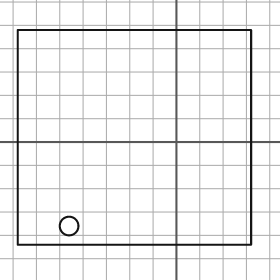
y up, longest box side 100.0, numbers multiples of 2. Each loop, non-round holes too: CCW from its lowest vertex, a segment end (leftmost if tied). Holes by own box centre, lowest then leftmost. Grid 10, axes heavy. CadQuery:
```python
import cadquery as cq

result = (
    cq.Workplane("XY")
    .moveTo(-68.0, -44.0)
    .lineTo(32.0, -44.0)
    .lineTo(32.0, 48.0)
    .lineTo(-68.0, 48.0)
    .close()
    .moveTo(-46.0, -36.0)
    .circle(4.0)
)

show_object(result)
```